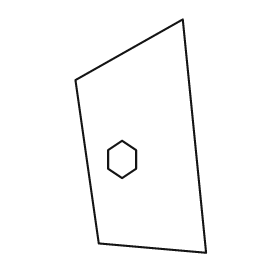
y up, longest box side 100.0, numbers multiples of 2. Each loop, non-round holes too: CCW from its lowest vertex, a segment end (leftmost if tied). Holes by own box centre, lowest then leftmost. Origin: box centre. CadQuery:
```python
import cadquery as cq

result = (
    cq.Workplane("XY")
    .moveTo(28.0, -50.0)
    .lineTo(18.0, 50.0)
    .lineTo(-28.0, 24.0)
    .lineTo(-18.0, -46.0)
    .close()
    .moveTo(-8.0, -18.0)
    .lineTo(-2.0, -14.0)
    .lineTo(-2.0, -6.0)
    .lineTo(-8.0, -2.0)
    .lineTo(-14.0, -6.0)
    .lineTo(-14.0, -14.0)
    .close()
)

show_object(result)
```